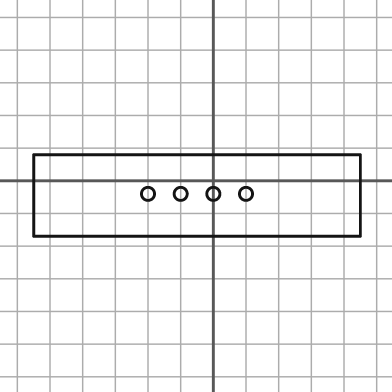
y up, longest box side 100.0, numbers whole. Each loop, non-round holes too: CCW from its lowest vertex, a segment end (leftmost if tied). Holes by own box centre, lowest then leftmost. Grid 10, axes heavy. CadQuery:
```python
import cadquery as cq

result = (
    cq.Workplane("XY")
    .moveTo(-55.0, -17.0)
    .lineTo(45.0, -17.0)
    .lineTo(45.0, 8.0)
    .lineTo(-55.0, 8.0)
    .close()
    .moveTo(-20.0, -4.0)
    .circle(2.0)
    .moveTo(-10.0, -4.0)
    .circle(2.0)
    .moveTo(0.0, -4.0)
    .circle(2.0)
    .moveTo(10.0, -4.0)
    .circle(2.0)
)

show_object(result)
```